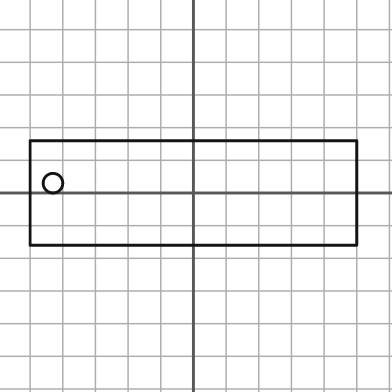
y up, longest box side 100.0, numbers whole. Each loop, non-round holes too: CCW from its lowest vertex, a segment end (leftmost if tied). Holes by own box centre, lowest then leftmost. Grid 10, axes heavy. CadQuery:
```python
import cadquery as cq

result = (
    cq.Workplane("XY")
    .moveTo(-50.0, -16.0)
    .lineTo(50.0, -16.0)
    .lineTo(50.0, 16.0)
    .lineTo(-50.0, 16.0)
    .close()
    .moveTo(-43.0, 3.0)
    .circle(3.0)
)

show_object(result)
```